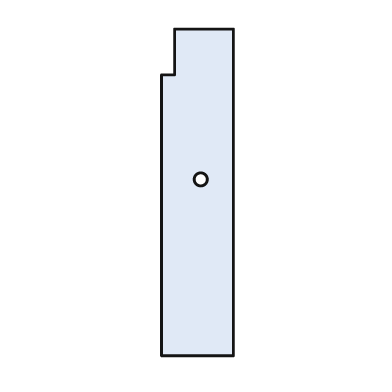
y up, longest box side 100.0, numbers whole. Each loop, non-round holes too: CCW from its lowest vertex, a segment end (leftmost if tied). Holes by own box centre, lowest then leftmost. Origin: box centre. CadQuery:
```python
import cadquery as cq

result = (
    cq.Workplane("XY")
    .moveTo(-11.0, -50.0)
    .lineTo(11.0, -50.0)
    .lineTo(11.0, 50.0)
    .lineTo(-7.0, 50.0)
    .lineTo(-7.0, 36.0)
    .lineTo(-11.0, 36.0)
    .close()
    .moveTo(1.0, 4.0)
    .circle(2.0)
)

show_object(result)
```